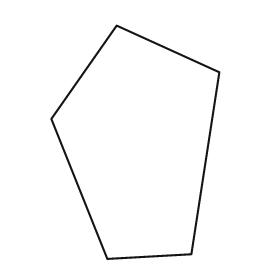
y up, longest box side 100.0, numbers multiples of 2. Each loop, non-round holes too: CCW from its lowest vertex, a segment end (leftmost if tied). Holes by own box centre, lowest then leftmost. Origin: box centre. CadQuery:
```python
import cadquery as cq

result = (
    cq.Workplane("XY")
    .moveTo(-12.0, -50.0)
    .lineTo(24.0, -48.0)
    .lineTo(36.0, 30.0)
    .lineTo(-8.0, 50.0)
    .lineTo(-36.0, 10.0)
    .close()
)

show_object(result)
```